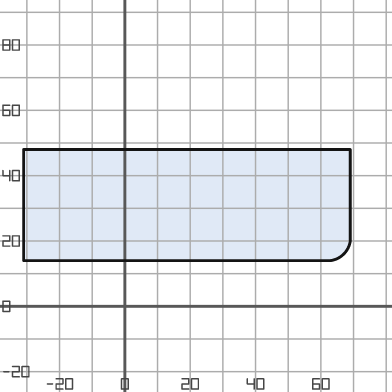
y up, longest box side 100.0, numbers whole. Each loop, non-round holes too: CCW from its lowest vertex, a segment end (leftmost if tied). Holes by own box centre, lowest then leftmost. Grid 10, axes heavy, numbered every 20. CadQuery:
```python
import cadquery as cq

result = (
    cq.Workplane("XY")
    .moveTo(-31.0, 14.0)
    .lineTo(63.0, 14.0)
    .threePointArc((67.0, 16.0), (69.0, 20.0))
    .lineTo(69.0, 48.0)
    .lineTo(-31.0, 48.0)
    .close()
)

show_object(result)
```